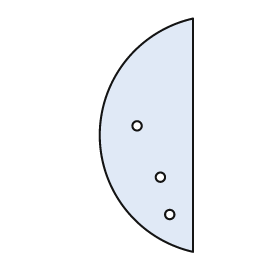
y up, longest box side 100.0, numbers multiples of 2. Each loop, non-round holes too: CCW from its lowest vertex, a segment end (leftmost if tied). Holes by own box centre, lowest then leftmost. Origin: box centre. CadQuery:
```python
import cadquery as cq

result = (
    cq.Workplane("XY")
    .moveTo(20.0, -50.0)
    .lineTo(20.0, 50.0)
    .threePointArc((-20.0, 0.0), (20.0, -50.0))
    .close()
    .moveTo(10.0, -34.0)
    .circle(2.0)
    .moveTo(6.0, -18.0)
    .circle(2.0)
    .moveTo(-4.0, 4.0)
    .circle(2.0)
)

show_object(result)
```